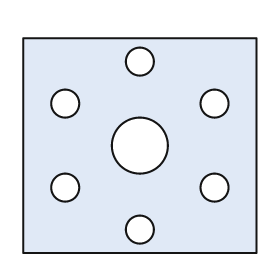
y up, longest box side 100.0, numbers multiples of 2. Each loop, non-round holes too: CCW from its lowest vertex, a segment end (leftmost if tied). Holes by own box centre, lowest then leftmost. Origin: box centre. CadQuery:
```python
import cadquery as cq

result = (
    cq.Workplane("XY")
    .moveTo(-50.0, -46.0)
    .lineTo(50.0, -46.0)
    .lineTo(50.0, 46.0)
    .lineTo(-50.0, 46.0)
    .close()
    .moveTo(0.0, -36.0)
    .circle(6.0)
    .moveTo(-32.0, -18.0)
    .circle(6.0)
    .moveTo(32.0, -18.0)
    .circle(6.0)
    .moveTo(0.0, 0.0)
    .circle(12.0)
    .moveTo(-32.0, 18.0)
    .circle(6.0)
    .moveTo(32.0, 18.0)
    .circle(6.0)
    .moveTo(0.0, 36.0)
    .circle(6.0)
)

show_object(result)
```